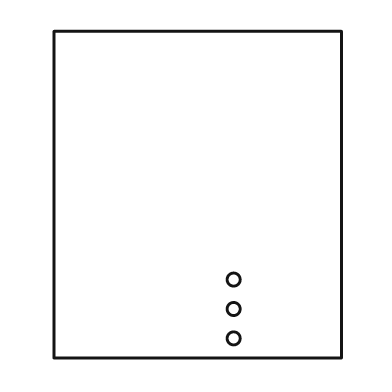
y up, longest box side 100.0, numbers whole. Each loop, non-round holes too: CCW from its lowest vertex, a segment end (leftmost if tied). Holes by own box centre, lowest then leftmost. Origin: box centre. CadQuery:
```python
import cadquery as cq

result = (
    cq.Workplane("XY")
    .moveTo(-44.0, -50.0)
    .lineTo(44.0, -50.0)
    .lineTo(44.0, 50.0)
    .lineTo(-44.0, 50.0)
    .close()
    .moveTo(11.0, -44.0)
    .circle(2.0)
    .moveTo(11.0, -35.0)
    .circle(2.0)
    .moveTo(11.0, -26.0)
    .circle(2.0)
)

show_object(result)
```